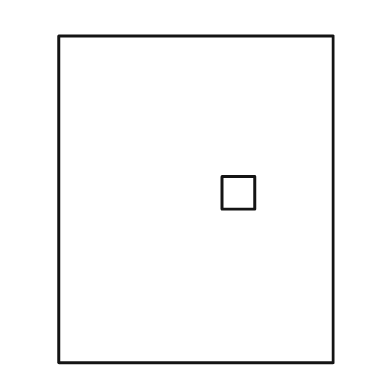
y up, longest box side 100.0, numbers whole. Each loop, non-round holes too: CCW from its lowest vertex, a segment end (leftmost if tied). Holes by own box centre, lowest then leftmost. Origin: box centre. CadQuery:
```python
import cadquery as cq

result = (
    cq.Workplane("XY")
    .moveTo(-42.0, -50.0)
    .lineTo(42.0, -50.0)
    .lineTo(42.0, 50.0)
    .lineTo(-42.0, 50.0)
    .close()
    .moveTo(8.0, -3.0)
    .lineTo(18.0, -3.0)
    .lineTo(18.0, 7.0)
    .lineTo(8.0, 7.0)
    .close()
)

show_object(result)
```